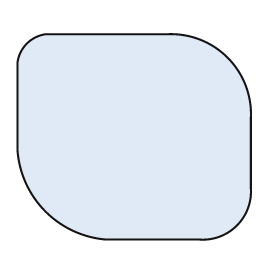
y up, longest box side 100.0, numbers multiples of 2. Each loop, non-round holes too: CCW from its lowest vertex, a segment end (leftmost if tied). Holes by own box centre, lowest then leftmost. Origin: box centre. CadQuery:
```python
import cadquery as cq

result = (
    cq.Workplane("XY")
    .moveTo(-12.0, -44.0)
    .lineTo(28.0, -44.0)
    .threePointArc((44.0, -38.0), (50.0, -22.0))
    .lineTo(50.0, 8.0)
    .threePointArc((40.0, 34.0), (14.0, 44.0))
    .lineTo(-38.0, 44.0)
    .threePointArc((-46.0, 40.0), (-50.0, 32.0))
    .lineTo(-50.0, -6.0)
    .threePointArc((-38.0, -32.0), (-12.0, -44.0))
    .close()
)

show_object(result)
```